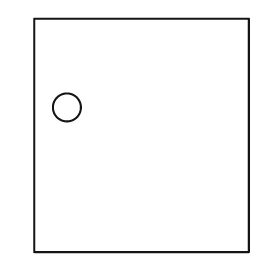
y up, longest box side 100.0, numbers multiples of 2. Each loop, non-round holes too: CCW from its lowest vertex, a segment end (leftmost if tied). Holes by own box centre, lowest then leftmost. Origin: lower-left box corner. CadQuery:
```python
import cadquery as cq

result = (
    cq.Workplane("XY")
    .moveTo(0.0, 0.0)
    .lineTo(92.0, 0.0)
    .lineTo(92.0, 100.0)
    .lineTo(0.0, 100.0)
    .close()
    .moveTo(14.0, 62.0)
    .circle(6.0)
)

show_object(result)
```